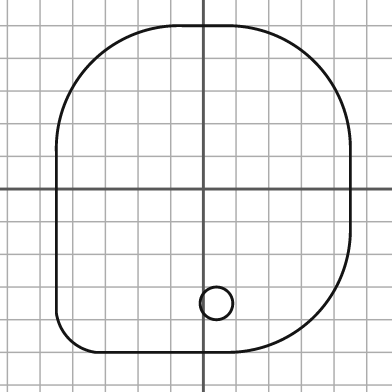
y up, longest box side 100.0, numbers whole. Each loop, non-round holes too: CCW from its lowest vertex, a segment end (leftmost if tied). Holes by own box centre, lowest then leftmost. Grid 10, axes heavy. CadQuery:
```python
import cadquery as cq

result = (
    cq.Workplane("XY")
    .moveTo(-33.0, -50.0)
    .lineTo(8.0, -50.0)
    .threePointArc((34.0, -39.0), (45.0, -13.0))
    .lineTo(45.0, 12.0)
    .threePointArc((34.0, 39.0), (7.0, 50.0))
    .lineTo(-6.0, 50.0)
    .threePointArc((-34.0, 39.0), (-45.0, 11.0))
    .lineTo(-45.0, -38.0)
    .threePointArc((-41.0, -46.0), (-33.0, -50.0))
    .close()
    .moveTo(4.0, -35.0)
    .circle(5.0)
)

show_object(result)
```